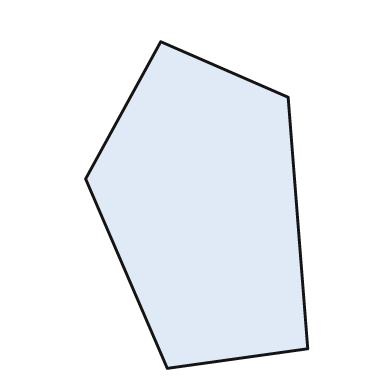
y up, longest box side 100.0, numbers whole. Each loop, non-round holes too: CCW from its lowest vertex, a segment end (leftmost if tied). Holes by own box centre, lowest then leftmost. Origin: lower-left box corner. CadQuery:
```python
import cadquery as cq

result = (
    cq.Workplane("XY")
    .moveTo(25.0, 0.0)
    .lineTo(68.0, 6.0)
    .lineTo(62.0, 83.0)
    .lineTo(23.0, 100.0)
    .lineTo(0.0, 58.0)
    .close()
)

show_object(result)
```